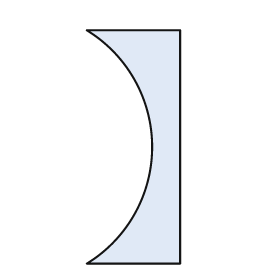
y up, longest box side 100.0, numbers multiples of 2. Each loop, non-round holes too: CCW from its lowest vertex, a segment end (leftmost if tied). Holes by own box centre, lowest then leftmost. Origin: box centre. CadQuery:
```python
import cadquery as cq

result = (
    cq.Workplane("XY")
    .moveTo(-20.0, -50.0)
    .lineTo(20.0, -50.0)
    .lineTo(20.0, 50.0)
    .lineTo(-20.0, 50.0)
    .threePointArc((8.0, 0.0), (-20.0, -50.0))
    .close()
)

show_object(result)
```